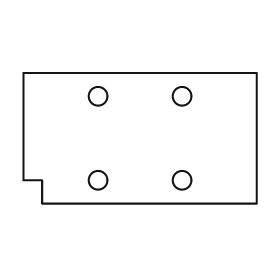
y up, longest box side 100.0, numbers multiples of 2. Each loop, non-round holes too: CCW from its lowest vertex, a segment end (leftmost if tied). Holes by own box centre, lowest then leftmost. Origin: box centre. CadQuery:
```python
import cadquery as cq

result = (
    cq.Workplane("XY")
    .moveTo(-42.0, -28.0)
    .lineTo(50.0, -28.0)
    .lineTo(50.0, 28.0)
    .lineTo(-50.0, 28.0)
    .lineTo(-50.0, -18.0)
    .lineTo(-42.0, -18.0)
    .close()
    .moveTo(-18.0, -18.0)
    .circle(4.0)
    .moveTo(18.0, -18.0)
    .circle(4.0)
    .moveTo(-18.0, 18.0)
    .circle(4.0)
    .moveTo(18.0, 18.0)
    .circle(4.0)
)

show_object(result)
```